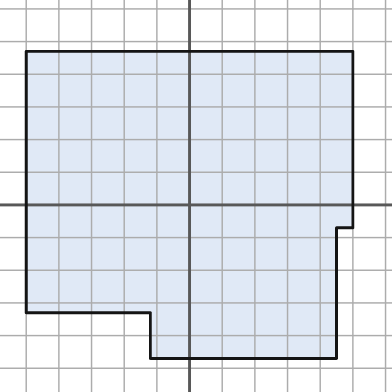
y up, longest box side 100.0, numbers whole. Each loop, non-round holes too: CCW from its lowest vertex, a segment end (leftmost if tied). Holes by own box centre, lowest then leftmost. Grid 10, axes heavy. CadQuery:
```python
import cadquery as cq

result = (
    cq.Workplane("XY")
    .moveTo(-12.0, -47.0)
    .lineTo(45.0, -47.0)
    .lineTo(45.0, -7.0)
    .lineTo(50.0, -7.0)
    .lineTo(50.0, 47.0)
    .lineTo(-50.0, 47.0)
    .lineTo(-50.0, -33.0)
    .lineTo(-12.0, -33.0)
    .close()
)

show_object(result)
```